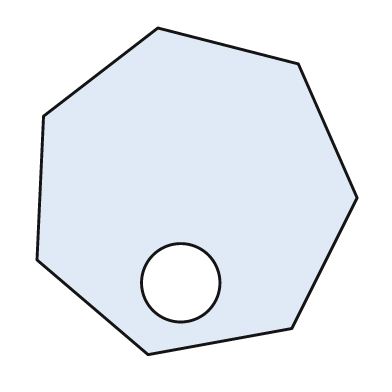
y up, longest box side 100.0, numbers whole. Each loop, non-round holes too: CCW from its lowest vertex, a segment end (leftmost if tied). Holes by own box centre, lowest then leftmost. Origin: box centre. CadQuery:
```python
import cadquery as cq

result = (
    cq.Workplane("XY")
    .moveTo(-15.0, -50.0)
    .lineTo(29.0, -42.0)
    .lineTo(49.0, -2.0)
    .lineTo(31.0, 39.0)
    .lineTo(-12.0, 50.0)
    .lineTo(-47.0, 23.0)
    .lineTo(-49.0, -21.0)
    .close()
    .moveTo(-5.0, -28.0)
    .circle(12.0)
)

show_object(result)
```